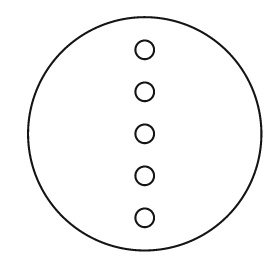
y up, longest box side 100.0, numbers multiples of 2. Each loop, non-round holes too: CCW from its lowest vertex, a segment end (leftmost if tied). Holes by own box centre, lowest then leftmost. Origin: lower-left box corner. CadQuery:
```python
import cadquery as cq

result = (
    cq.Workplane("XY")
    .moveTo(50.0, 50.0)
    .circle(50.0)
    .moveTo(50.0, 14.0)
    .circle(4.0)
    .moveTo(50.0, 32.0)
    .circle(4.0)
    .moveTo(50.0, 50.0)
    .circle(4.0)
    .moveTo(50.0, 68.0)
    .circle(4.0)
    .moveTo(50.0, 86.0)
    .circle(4.0)
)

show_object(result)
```